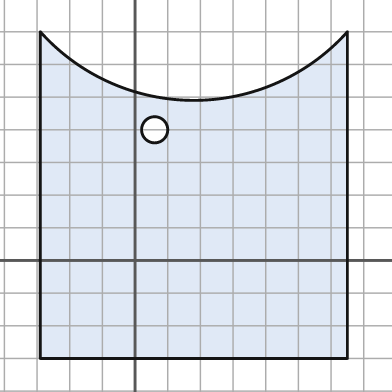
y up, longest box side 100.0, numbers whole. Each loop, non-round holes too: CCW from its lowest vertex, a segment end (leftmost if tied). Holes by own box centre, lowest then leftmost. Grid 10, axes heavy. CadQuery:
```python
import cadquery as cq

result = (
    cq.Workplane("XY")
    .moveTo(-29.0, -30.0)
    .lineTo(65.0, -30.0)
    .lineTo(65.0, 70.0)
    .threePointArc((18.0, 49.0), (-29.0, 70.0))
    .close()
    .moveTo(6.0, 40.0)
    .circle(4.0)
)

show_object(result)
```